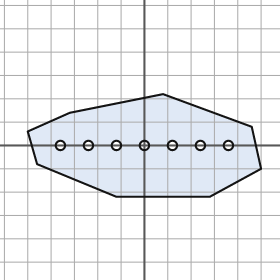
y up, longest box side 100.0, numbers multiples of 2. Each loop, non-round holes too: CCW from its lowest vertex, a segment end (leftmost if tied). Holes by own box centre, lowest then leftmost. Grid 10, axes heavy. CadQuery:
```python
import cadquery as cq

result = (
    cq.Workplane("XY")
    .moveTo(-12.0, -22.0)
    .lineTo(28.0, -22.0)
    .lineTo(50.0, -10.0)
    .lineTo(46.0, 8.0)
    .lineTo(8.0, 22.0)
    .lineTo(-32.0, 14.0)
    .lineTo(-50.0, 6.0)
    .lineTo(-46.0, -8.0)
    .close()
    .moveTo(-36.0, 0.0)
    .circle(2.0)
    .moveTo(-24.0, 0.0)
    .circle(2.0)
    .moveTo(-12.0, 0.0)
    .circle(2.0)
    .moveTo(0.0, 0.0)
    .circle(2.0)
    .moveTo(12.0, 0.0)
    .circle(2.0)
    .moveTo(24.0, 0.0)
    .circle(2.0)
    .moveTo(36.0, 0.0)
    .circle(2.0)
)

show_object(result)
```